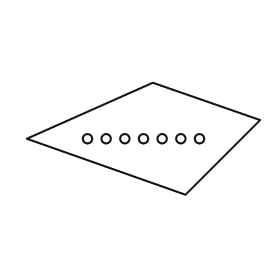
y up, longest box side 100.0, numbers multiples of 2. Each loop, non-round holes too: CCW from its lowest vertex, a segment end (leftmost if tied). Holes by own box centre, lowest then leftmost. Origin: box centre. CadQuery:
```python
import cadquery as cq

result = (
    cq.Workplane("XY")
    .moveTo(18.0, -24.0)
    .lineTo(50.0, 8.0)
    .lineTo(4.0, 24.0)
    .lineTo(-50.0, 0.0)
    .close()
    .moveTo(-24.0, 0.0)
    .circle(2.0)
    .moveTo(-16.0, 0.0)
    .circle(2.0)
    .moveTo(-8.0, 0.0)
    .circle(2.0)
    .moveTo(0.0, 0.0)
    .circle(2.0)
    .moveTo(8.0, 0.0)
    .circle(2.0)
    .moveTo(16.0, 0.0)
    .circle(2.0)
    .moveTo(24.0, 0.0)
    .circle(2.0)
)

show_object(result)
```